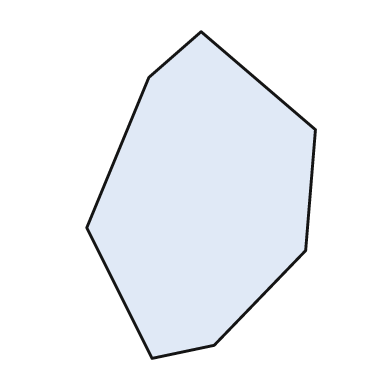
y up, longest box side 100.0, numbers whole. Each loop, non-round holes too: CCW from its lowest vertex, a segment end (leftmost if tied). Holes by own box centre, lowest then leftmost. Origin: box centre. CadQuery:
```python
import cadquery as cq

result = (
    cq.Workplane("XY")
    .moveTo(-15.0, -50.0)
    .lineTo(4.0, -46.0)
    .lineTo(32.0, -17.0)
    .lineTo(35.0, 20.0)
    .lineTo(0.0, 50.0)
    .lineTo(-16.0, 36.0)
    .lineTo(-35.0, -10.0)
    .close()
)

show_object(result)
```